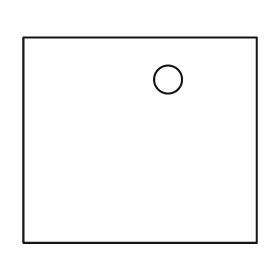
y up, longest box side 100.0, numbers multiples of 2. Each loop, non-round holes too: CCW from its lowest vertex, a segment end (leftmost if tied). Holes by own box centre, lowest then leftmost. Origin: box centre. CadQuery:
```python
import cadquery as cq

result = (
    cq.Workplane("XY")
    .moveTo(-50.0, -44.0)
    .lineTo(50.0, -44.0)
    .lineTo(50.0, 44.0)
    .lineTo(-50.0, 44.0)
    .close()
    .moveTo(12.0, 26.0)
    .circle(6.0)
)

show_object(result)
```